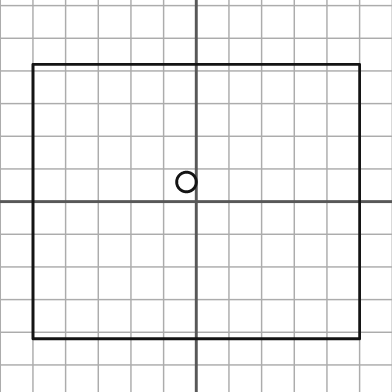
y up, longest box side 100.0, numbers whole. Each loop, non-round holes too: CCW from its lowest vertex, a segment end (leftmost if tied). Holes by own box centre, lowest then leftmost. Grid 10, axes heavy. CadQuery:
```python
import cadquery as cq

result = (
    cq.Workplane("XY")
    .moveTo(-50.0, -42.0)
    .lineTo(50.0, -42.0)
    .lineTo(50.0, 42.0)
    .lineTo(-50.0, 42.0)
    .close()
    .moveTo(-3.0, 6.0)
    .circle(3.0)
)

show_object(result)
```